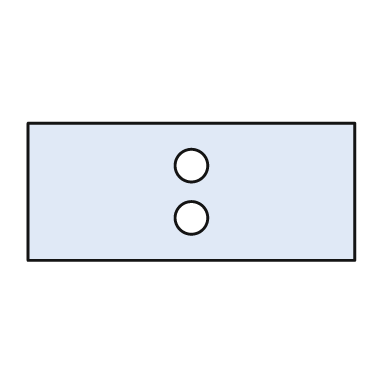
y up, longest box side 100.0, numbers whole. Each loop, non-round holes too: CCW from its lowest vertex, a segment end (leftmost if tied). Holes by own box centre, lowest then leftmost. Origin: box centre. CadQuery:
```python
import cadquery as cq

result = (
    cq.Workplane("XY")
    .moveTo(-50.0, -21.0)
    .lineTo(50.0, -21.0)
    .lineTo(50.0, 21.0)
    .lineTo(-50.0, 21.0)
    .close()
    .moveTo(0.0, -8.0)
    .circle(5.0)
    .moveTo(0.0, 8.0)
    .circle(5.0)
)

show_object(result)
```